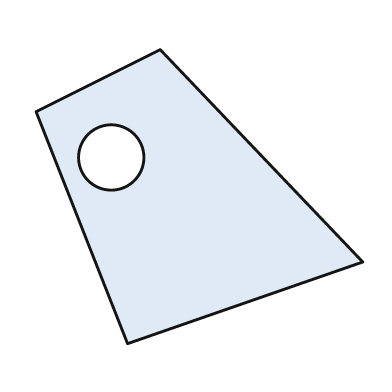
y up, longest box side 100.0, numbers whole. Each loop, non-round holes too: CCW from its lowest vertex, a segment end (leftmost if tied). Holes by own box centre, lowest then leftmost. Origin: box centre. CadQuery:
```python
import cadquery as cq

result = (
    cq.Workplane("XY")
    .moveTo(-22.0, -45.0)
    .lineTo(50.0, -20.0)
    .lineTo(-12.0, 45.0)
    .lineTo(-50.0, 26.0)
    .close()
    .moveTo(-27.0, 12.0)
    .circle(10.0)
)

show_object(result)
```